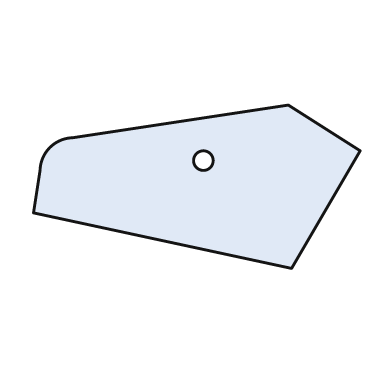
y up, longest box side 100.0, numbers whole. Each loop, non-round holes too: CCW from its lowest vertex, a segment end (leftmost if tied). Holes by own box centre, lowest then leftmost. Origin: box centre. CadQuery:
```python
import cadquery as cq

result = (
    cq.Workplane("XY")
    .moveTo(29.0, -25.0)
    .lineTo(50.0, 11.0)
    .lineTo(28.0, 25.0)
    .lineTo(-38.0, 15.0)
    .threePointArc((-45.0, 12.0), (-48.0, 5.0))
    .lineTo(-50.0, -8.0)
    .close()
    .moveTo(2.0, 8.0)
    .circle(3.0)
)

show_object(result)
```